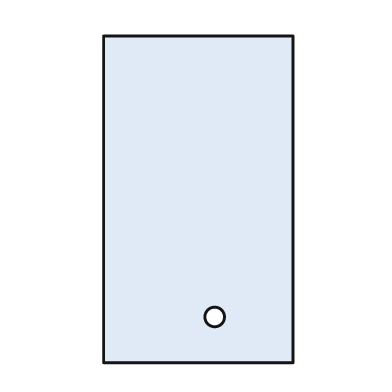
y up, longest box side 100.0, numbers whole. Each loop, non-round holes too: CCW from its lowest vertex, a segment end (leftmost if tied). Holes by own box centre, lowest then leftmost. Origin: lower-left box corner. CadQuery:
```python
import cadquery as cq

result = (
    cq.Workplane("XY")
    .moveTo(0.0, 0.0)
    .lineTo(58.0, 0.0)
    .lineTo(58.0, 100.0)
    .lineTo(0.0, 100.0)
    .close()
    .moveTo(34.0, 14.0)
    .circle(3.0)
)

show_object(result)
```